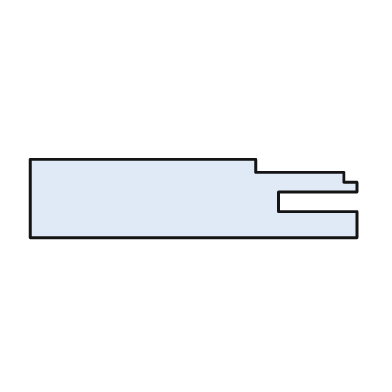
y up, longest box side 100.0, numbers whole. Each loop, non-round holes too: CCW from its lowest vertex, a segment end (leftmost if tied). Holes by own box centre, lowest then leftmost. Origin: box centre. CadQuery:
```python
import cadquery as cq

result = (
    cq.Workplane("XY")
    .moveTo(-50.0, -12.0)
    .lineTo(50.0, -12.0)
    .lineTo(50.0, -4.0)
    .lineTo(26.0, -4.0)
    .lineTo(26.0, 2.0)
    .lineTo(50.0, 2.0)
    .lineTo(50.0, 5.0)
    .lineTo(46.0, 5.0)
    .lineTo(46.0, 8.0)
    .lineTo(19.0, 8.0)
    .lineTo(19.0, 12.0)
    .lineTo(-50.0, 12.0)
    .close()
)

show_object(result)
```